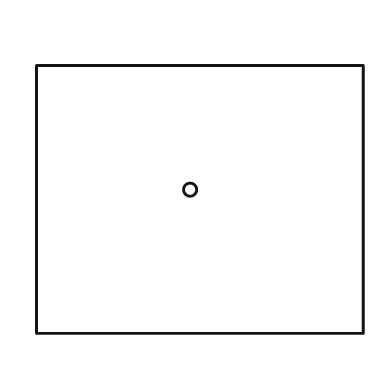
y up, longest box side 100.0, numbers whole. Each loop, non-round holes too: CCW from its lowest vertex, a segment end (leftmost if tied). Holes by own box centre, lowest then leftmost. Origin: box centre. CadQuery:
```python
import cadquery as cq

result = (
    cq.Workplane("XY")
    .moveTo(-50.0, -41.0)
    .lineTo(50.0, -41.0)
    .lineTo(50.0, 41.0)
    .lineTo(-50.0, 41.0)
    .close()
    .moveTo(-3.0, 3.0)
    .circle(2.0)
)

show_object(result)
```